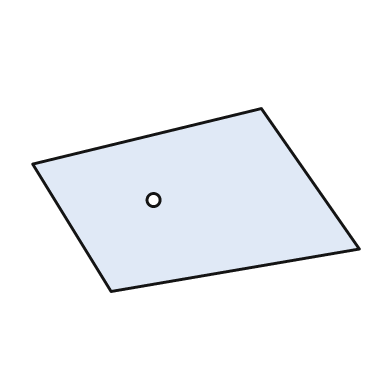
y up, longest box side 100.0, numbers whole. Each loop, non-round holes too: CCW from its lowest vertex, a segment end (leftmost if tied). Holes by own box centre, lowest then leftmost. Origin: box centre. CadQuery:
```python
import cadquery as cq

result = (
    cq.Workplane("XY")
    .moveTo(-26.0, -28.0)
    .lineTo(50.0, -15.0)
    .lineTo(20.0, 28.0)
    .lineTo(-50.0, 11.0)
    .close()
    .moveTo(-13.0, 0.0)
    .circle(2.0)
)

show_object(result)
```